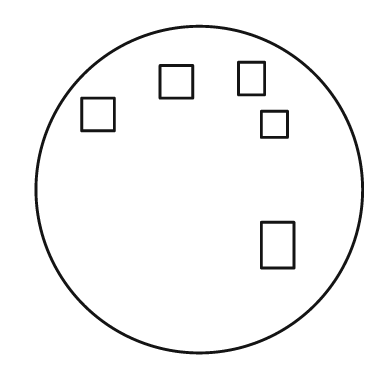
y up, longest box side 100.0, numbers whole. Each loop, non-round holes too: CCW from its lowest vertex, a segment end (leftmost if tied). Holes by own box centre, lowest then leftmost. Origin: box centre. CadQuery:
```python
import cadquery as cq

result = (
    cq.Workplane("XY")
    .moveTo(0.0, 0.0)
    .circle(50.0)
    .moveTo(19.0, -24.0)
    .lineTo(29.0, -24.0)
    .lineTo(29.0, -10.0)
    .lineTo(19.0, -10.0)
    .close()
    .moveTo(19.0, 16.0)
    .lineTo(27.0, 16.0)
    .lineTo(27.0, 24.0)
    .lineTo(19.0, 24.0)
    .close()
    .moveTo(-36.0, 18.0)
    .lineTo(-26.0, 18.0)
    .lineTo(-26.0, 28.0)
    .lineTo(-36.0, 28.0)
    .close()
    .moveTo(-12.0, 28.0)
    .lineTo(-2.0, 28.0)
    .lineTo(-2.0, 38.0)
    .lineTo(-12.0, 38.0)
    .close()
    .moveTo(12.0, 29.0)
    .lineTo(20.0, 29.0)
    .lineTo(20.0, 39.0)
    .lineTo(12.0, 39.0)
    .close()
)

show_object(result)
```